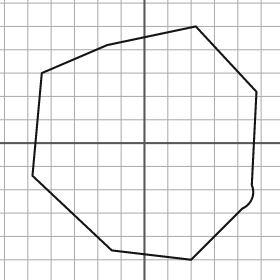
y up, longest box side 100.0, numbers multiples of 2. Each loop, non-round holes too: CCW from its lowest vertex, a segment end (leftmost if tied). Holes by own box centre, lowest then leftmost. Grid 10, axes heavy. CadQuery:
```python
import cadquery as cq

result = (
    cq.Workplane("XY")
    .moveTo(20.0, -50.0)
    .lineTo(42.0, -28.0)
    .threePointArc((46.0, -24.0), (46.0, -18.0))
    .lineTo(48.0, 22.0)
    .lineTo(22.0, 50.0)
    .lineTo(-16.0, 42.0)
    .lineTo(-44.0, 30.0)
    .lineTo(-48.0, -14.0)
    .lineTo(-14.0, -46.0)
    .close()
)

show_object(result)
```